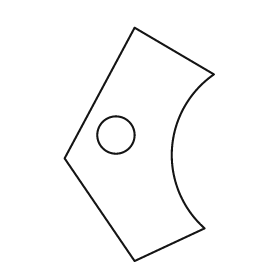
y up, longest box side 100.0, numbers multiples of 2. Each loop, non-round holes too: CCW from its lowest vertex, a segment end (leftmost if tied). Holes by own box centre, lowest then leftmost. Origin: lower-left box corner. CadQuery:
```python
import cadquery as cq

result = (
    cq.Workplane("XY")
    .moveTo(30.0, 0.0)
    .lineTo(60.0, 14.0)
    .threePointArc((46.0, 48.0), (64.0, 80.0))
    .lineTo(30.0, 100.0)
    .lineTo(0.0, 44.0)
    .close()
    .moveTo(22.0, 54.0)
    .circle(8.0)
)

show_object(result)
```